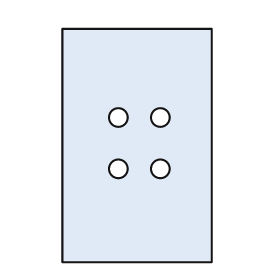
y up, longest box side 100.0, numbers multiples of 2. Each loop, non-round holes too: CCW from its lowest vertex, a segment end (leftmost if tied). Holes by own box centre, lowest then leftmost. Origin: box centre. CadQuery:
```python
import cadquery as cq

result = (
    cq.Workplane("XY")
    .moveTo(-32.0, -50.0)
    .lineTo(32.0, -50.0)
    .lineTo(32.0, 50.0)
    .lineTo(-32.0, 50.0)
    .close()
    .moveTo(-8.0, -10.0)
    .circle(4.0)
    .moveTo(10.0, -10.0)
    .circle(4.0)
    .moveTo(-8.0, 12.0)
    .circle(4.0)
    .moveTo(10.0, 12.0)
    .circle(4.0)
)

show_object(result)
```